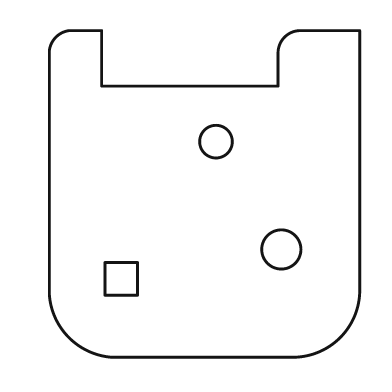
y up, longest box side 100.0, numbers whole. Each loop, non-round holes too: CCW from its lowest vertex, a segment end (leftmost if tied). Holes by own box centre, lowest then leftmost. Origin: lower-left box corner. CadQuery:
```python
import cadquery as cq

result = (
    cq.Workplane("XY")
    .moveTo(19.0, 0.0)
    .lineTo(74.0, 0.0)
    .threePointArc((89.0, 6.0), (95.0, 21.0))
    .lineTo(95.0, 100.0)
    .lineTo(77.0, 100.0)
    .threePointArc((72.0, 98.0), (70.0, 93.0))
    .lineTo(70.0, 83.0)
    .lineTo(16.0, 83.0)
    .lineTo(16.0, 100.0)
    .lineTo(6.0, 100.0)
    .threePointArc((2.0, 98.0), (0.0, 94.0))
    .lineTo(0.0, 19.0)
    .threePointArc((6.0, 6.0), (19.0, 0.0))
    .close()
    .moveTo(17.0, 19.0)
    .lineTo(27.0, 19.0)
    .lineTo(27.0, 29.0)
    .lineTo(17.0, 29.0)
    .close()
    .moveTo(71.0, 33.0)
    .circle(6.0)
    .moveTo(51.0, 66.0)
    .circle(5.0)
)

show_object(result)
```